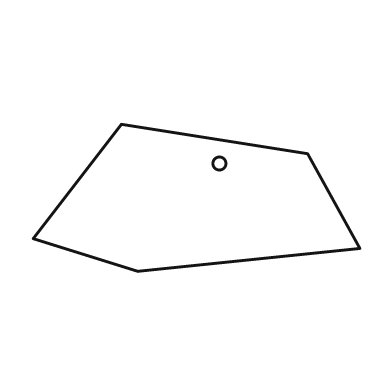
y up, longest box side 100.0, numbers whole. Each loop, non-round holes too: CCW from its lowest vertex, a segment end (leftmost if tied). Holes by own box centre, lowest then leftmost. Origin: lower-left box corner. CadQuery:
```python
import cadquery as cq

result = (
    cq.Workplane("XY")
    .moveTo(32.0, 0.0)
    .lineTo(100.0, 7.0)
    .lineTo(84.0, 36.0)
    .lineTo(27.0, 45.0)
    .lineTo(0.0, 10.0)
    .close()
    .moveTo(57.0, 33.0)
    .circle(2.0)
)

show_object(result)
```